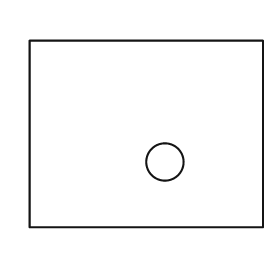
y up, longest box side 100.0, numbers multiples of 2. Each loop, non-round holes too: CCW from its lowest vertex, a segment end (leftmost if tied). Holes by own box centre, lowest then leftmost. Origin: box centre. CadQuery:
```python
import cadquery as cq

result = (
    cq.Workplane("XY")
    .moveTo(-50.0, -40.0)
    .lineTo(50.0, -40.0)
    .lineTo(50.0, 40.0)
    .lineTo(-50.0, 40.0)
    .close()
    .moveTo(8.0, -12.0)
    .circle(8.0)
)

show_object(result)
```